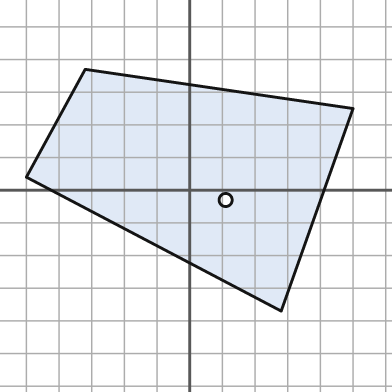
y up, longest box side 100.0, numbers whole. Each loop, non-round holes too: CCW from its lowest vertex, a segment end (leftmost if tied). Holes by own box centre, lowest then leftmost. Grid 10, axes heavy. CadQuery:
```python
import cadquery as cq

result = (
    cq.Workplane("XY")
    .moveTo(28.0, -37.0)
    .lineTo(50.0, 25.0)
    .lineTo(-32.0, 37.0)
    .lineTo(-50.0, 4.0)
    .close()
    .moveTo(11.0, -3.0)
    .circle(2.0)
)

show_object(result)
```